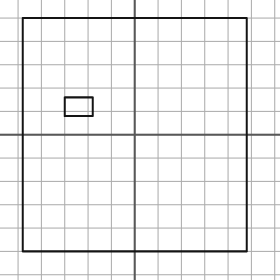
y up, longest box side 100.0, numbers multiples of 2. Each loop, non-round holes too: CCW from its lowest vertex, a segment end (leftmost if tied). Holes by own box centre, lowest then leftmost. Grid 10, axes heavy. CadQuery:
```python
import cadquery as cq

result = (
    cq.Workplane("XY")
    .moveTo(-48.0, -50.0)
    .lineTo(48.0, -50.0)
    .lineTo(48.0, 50.0)
    .lineTo(-48.0, 50.0)
    .close()
    .moveTo(-30.0, 8.0)
    .lineTo(-18.0, 8.0)
    .lineTo(-18.0, 16.0)
    .lineTo(-30.0, 16.0)
    .close()
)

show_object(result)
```